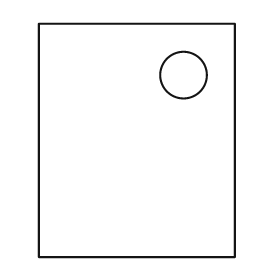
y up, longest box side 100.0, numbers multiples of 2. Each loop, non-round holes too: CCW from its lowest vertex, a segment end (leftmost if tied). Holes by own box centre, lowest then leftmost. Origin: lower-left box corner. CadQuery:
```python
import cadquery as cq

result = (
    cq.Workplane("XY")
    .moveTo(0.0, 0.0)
    .lineTo(84.0, 0.0)
    .lineTo(84.0, 100.0)
    .lineTo(0.0, 100.0)
    .close()
    .moveTo(62.0, 78.0)
    .circle(10.0)
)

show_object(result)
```